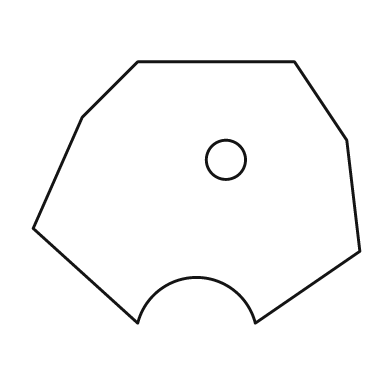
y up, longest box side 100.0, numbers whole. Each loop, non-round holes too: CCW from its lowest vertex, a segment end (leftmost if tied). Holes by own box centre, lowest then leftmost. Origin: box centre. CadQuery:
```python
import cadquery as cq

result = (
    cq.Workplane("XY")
    .moveTo(-18.0, -40.0)
    .threePointArc((0.0, -26.0), (18.0, -40.0))
    .lineTo(50.0, -18.0)
    .lineTo(46.0, 16.0)
    .lineTo(30.0, 40.0)
    .lineTo(-18.0, 40.0)
    .lineTo(-35.0, 23.0)
    .lineTo(-50.0, -11.0)
    .close()
    .moveTo(9.0, 10.0)
    .circle(6.0)
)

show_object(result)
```